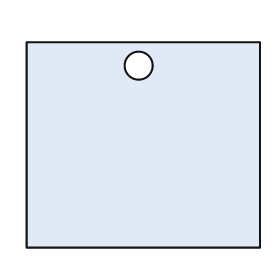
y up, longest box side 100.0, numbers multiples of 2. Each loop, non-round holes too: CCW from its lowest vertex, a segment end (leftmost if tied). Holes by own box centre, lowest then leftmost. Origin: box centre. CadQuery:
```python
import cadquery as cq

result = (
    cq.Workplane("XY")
    .moveTo(-50.0, -44.0)
    .lineTo(50.0, -44.0)
    .lineTo(50.0, 44.0)
    .lineTo(-50.0, 44.0)
    .close()
    .moveTo(-2.0, 34.0)
    .circle(6.0)
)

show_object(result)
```